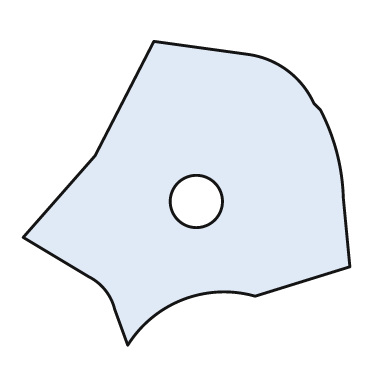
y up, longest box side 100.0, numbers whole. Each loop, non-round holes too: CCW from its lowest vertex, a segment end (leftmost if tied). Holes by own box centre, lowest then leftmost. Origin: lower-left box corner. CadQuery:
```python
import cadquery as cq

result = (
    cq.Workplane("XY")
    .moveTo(32.0, 0.0)
    .threePointArc((49.0, 14.0), (71.0, 15.0))
    .lineTo(100.0, 24.0)
    .lineTo(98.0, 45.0)
    .threePointArc((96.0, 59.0), (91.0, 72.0))
    .lineTo(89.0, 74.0)
    .threePointArc((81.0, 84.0), (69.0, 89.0))
    .lineTo(40.0, 93.0)
    .lineTo(22.0, 58.0)
    .lineTo(0.0, 33.0)
    .lineTo(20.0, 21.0)
    .threePointArc((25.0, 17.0), (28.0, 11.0))
    .close()
    .moveTo(53.0, 44.0)
    .circle(8.0)
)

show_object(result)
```